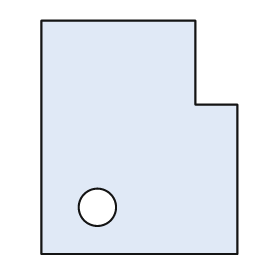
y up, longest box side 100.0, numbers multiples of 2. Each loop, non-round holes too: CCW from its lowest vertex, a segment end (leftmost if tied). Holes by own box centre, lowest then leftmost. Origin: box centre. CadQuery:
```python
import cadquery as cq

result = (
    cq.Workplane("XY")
    .moveTo(-42.0, -50.0)
    .lineTo(42.0, -50.0)
    .lineTo(42.0, 14.0)
    .lineTo(24.0, 14.0)
    .lineTo(24.0, 50.0)
    .lineTo(-42.0, 50.0)
    .close()
    .moveTo(-18.0, -30.0)
    .circle(8.0)
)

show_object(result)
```